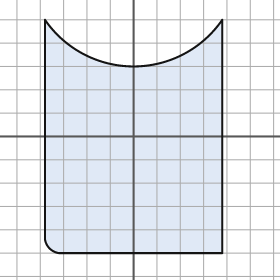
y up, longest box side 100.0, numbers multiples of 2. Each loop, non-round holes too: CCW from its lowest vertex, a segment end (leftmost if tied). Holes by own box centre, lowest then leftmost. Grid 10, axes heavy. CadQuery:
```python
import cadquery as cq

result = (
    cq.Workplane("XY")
    .moveTo(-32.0, -50.0)
    .lineTo(38.0, -50.0)
    .lineTo(38.0, 50.0)
    .threePointArc((0.0, 30.0), (-38.0, 50.0))
    .lineTo(-38.0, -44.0)
    .threePointArc((-36.0, -48.0), (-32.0, -50.0))
    .close()
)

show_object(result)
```